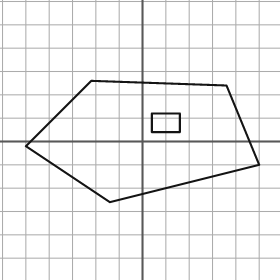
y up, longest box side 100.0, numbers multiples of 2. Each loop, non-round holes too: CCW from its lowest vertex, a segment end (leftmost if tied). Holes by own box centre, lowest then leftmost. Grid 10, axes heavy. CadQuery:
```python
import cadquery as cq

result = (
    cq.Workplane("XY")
    .moveTo(-14.0, -26.0)
    .lineTo(50.0, -10.0)
    .lineTo(36.0, 24.0)
    .lineTo(-22.0, 26.0)
    .lineTo(-50.0, -2.0)
    .close()
    .moveTo(4.0, 4.0)
    .lineTo(16.0, 4.0)
    .lineTo(16.0, 12.0)
    .lineTo(4.0, 12.0)
    .close()
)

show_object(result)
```